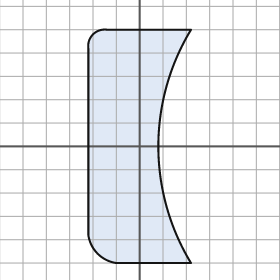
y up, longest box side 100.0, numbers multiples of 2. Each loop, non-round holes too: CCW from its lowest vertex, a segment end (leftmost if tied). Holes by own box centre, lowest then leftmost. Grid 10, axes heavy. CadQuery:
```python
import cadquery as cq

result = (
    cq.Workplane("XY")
    .moveTo(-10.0, -50.0)
    .lineTo(22.0, -50.0)
    .threePointArc((8.0, 0.0), (22.0, 50.0))
    .lineTo(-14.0, 50.0)
    .threePointArc((-20.0, 48.0), (-22.0, 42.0))
    .lineTo(-22.0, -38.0)
    .threePointArc((-18.0, -46.0), (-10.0, -50.0))
    .close()
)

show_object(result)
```